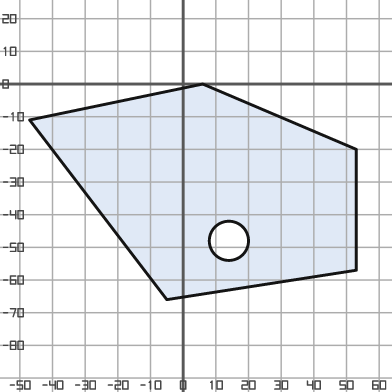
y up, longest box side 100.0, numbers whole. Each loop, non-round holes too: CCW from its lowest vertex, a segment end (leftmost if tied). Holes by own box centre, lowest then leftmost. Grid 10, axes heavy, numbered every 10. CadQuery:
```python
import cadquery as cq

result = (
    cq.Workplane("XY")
    .moveTo(-5.0, -66.0)
    .lineTo(53.0, -57.0)
    .lineTo(53.0, -20.0)
    .lineTo(6.0, 0.0)
    .lineTo(-47.0, -11.0)
    .close()
    .moveTo(14.0, -48.0)
    .circle(6.0)
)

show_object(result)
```